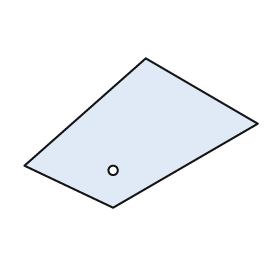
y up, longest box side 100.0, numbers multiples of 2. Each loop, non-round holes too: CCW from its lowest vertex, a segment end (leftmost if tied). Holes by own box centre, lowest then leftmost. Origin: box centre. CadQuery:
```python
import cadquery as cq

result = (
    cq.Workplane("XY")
    .moveTo(-12.0, -32.0)
    .lineTo(50.0, 4.0)
    .lineTo(2.0, 32.0)
    .lineTo(-50.0, -14.0)
    .close()
    .moveTo(-12.0, -16.0)
    .circle(2.0)
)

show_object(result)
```